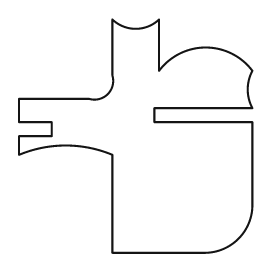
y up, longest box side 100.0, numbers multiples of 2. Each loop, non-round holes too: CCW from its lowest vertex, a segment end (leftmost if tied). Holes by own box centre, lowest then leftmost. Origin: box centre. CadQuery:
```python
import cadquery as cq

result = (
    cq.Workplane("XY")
    .moveTo(-10.0, -50.0)
    .lineTo(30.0, -50.0)
    .threePointArc((44.0, -44.0), (50.0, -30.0))
    .lineTo(50.0, 6.0)
    .lineTo(8.0, 6.0)
    .lineTo(8.0, 12.0)
    .lineTo(50.0, 12.0)
    .threePointArc((48.0, 20.0), (50.0, 28.0))
    .threePointArc((30.0, 38.0), (10.0, 28.0))
    .lineTo(10.0, 50.0)
    .threePointArc((0.0, 46.0), (-10.0, 50.0))
    .lineTo(-10.0, 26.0)
    .threePointArc((-12.0, 18.0), (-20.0, 16.0))
    .lineTo(-50.0, 16.0)
    .lineTo(-50.0, 6.0)
    .lineTo(-36.0, 6.0)
    .lineTo(-36.0, 0.0)
    .lineTo(-50.0, 0.0)
    .lineTo(-50.0, -8.0)
    .threePointArc((-30.0, -4.0), (-10.0, -8.0))
    .close()
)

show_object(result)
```